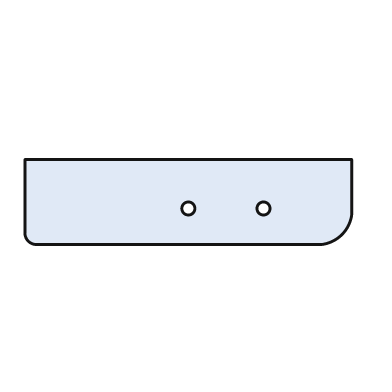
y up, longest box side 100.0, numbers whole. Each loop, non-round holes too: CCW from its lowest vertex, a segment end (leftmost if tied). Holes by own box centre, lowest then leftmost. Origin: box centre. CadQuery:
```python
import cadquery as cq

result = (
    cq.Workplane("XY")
    .moveTo(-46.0, -13.0)
    .lineTo(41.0, -13.0)
    .threePointArc((47.0, -10.0), (50.0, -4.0))
    .lineTo(50.0, 13.0)
    .lineTo(-50.0, 13.0)
    .lineTo(-50.0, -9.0)
    .threePointArc((-49.0, -12.0), (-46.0, -13.0))
    .close()
    .moveTo(0.0, -2.0)
    .circle(2.0)
    .moveTo(23.0, -2.0)
    .circle(2.0)
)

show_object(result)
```